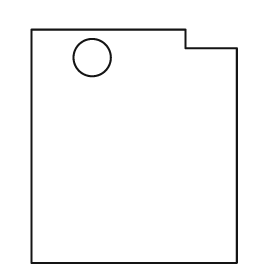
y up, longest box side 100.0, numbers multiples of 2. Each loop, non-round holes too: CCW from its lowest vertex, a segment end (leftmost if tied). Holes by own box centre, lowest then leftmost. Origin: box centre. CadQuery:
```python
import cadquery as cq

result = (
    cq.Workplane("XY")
    .moveTo(-44.0, -50.0)
    .lineTo(44.0, -50.0)
    .lineTo(44.0, 42.0)
    .lineTo(22.0, 42.0)
    .lineTo(22.0, 50.0)
    .lineTo(-44.0, 50.0)
    .close()
    .moveTo(-18.0, 38.0)
    .circle(8.0)
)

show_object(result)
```